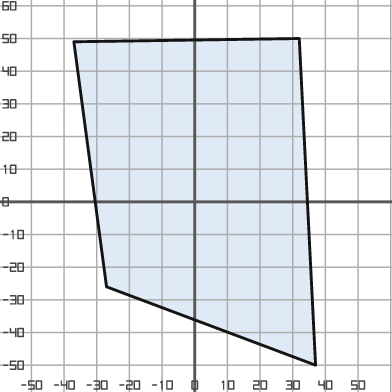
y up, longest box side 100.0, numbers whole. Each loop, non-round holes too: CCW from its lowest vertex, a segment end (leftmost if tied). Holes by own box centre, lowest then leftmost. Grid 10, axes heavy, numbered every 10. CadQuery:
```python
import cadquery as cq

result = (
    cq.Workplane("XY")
    .moveTo(37.0, -50.0)
    .lineTo(32.0, 50.0)
    .lineTo(-37.0, 49.0)
    .lineTo(-27.0, -26.0)
    .close()
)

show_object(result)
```